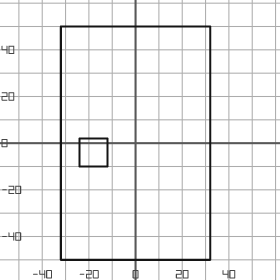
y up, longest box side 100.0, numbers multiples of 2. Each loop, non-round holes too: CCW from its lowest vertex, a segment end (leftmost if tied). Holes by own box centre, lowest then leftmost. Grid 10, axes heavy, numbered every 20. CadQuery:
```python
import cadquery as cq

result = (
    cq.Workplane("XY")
    .moveTo(-32.0, -50.0)
    .lineTo(32.0, -50.0)
    .lineTo(32.0, 50.0)
    .lineTo(-32.0, 50.0)
    .close()
    .moveTo(-24.0, -10.0)
    .lineTo(-12.0, -10.0)
    .lineTo(-12.0, 2.0)
    .lineTo(-24.0, 2.0)
    .close()
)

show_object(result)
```